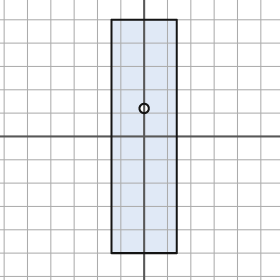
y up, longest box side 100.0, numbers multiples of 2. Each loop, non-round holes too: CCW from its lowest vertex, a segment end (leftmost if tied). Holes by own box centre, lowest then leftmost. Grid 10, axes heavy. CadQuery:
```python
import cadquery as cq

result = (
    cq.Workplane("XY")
    .moveTo(-14.0, -50.0)
    .lineTo(14.0, -50.0)
    .lineTo(14.0, 50.0)
    .lineTo(-14.0, 50.0)
    .close()
    .moveTo(0.0, 12.0)
    .circle(2.0)
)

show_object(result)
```